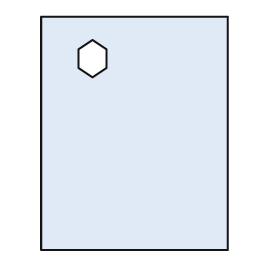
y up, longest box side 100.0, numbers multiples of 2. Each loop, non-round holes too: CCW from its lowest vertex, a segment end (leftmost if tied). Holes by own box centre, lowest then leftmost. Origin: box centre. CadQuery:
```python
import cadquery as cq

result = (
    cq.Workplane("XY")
    .moveTo(-40.0, -50.0)
    .lineTo(40.0, -50.0)
    .lineTo(40.0, 50.0)
    .lineTo(-40.0, 50.0)
    .close()
    .moveTo(-18.0, 24.0)
    .lineTo(-12.0, 28.0)
    .lineTo(-12.0, 36.0)
    .lineTo(-18.0, 40.0)
    .lineTo(-24.0, 36.0)
    .lineTo(-24.0, 28.0)
    .close()
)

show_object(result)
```